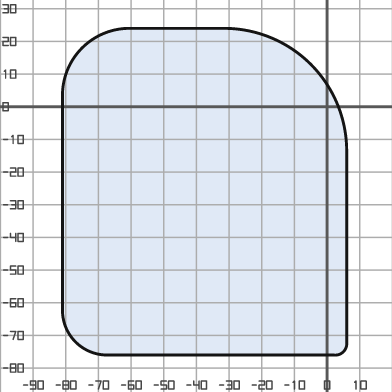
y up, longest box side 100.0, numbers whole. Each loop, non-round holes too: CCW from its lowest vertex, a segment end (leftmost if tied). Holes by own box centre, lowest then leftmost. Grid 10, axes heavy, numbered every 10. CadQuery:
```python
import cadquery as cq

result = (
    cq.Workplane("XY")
    .moveTo(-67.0, -76.0)
    .lineTo(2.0, -76.0)
    .threePointArc((5.0, -75.0), (6.0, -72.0))
    .lineTo(6.0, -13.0)
    .threePointArc((-5.0, 13.0), (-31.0, 24.0))
    .lineTo(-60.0, 24.0)
    .threePointArc((-75.0, 18.0), (-81.0, 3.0))
    .lineTo(-81.0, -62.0)
    .threePointArc((-77.0, -72.0), (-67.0, -76.0))
    .close()
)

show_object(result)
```